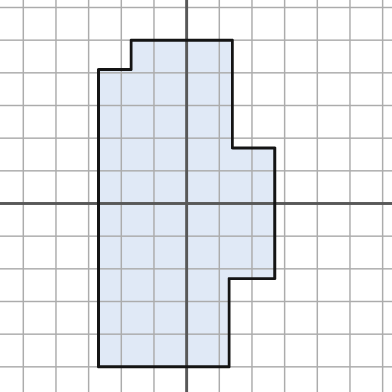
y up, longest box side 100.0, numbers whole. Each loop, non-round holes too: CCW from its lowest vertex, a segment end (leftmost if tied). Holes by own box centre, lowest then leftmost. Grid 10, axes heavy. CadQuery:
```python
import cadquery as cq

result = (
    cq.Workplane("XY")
    .moveTo(-27.0, -50.0)
    .lineTo(13.0, -50.0)
    .lineTo(13.0, -23.0)
    .lineTo(27.0, -23.0)
    .lineTo(27.0, 17.0)
    .lineTo(14.0, 17.0)
    .lineTo(14.0, 50.0)
    .lineTo(-17.0, 50.0)
    .lineTo(-17.0, 41.0)
    .lineTo(-27.0, 41.0)
    .close()
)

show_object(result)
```